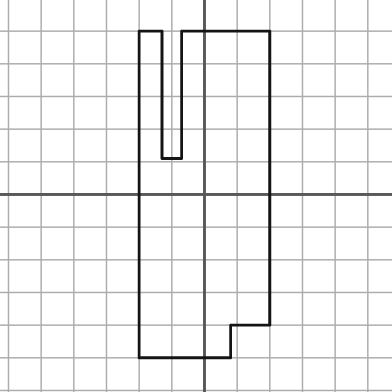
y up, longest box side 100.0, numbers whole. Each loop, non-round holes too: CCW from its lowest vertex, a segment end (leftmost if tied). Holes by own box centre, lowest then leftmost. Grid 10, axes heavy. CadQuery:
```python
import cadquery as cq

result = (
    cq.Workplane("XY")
    .moveTo(-20.0, -50.0)
    .lineTo(8.0, -50.0)
    .lineTo(8.0, -40.0)
    .lineTo(20.0, -40.0)
    .lineTo(20.0, 50.0)
    .lineTo(-7.0, 50.0)
    .lineTo(-7.0, 11.0)
    .lineTo(-13.0, 11.0)
    .lineTo(-13.0, 50.0)
    .lineTo(-20.0, 50.0)
    .close()
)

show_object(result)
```